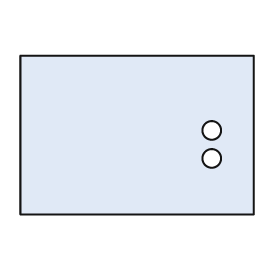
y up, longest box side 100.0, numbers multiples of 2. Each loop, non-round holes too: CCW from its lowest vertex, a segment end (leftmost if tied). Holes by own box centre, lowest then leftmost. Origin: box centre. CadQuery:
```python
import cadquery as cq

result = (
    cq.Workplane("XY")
    .moveTo(-50.0, -34.0)
    .lineTo(50.0, -34.0)
    .lineTo(50.0, 34.0)
    .lineTo(-50.0, 34.0)
    .close()
    .moveTo(32.0, -10.0)
    .circle(4.0)
    .moveTo(32.0, 2.0)
    .circle(4.0)
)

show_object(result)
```